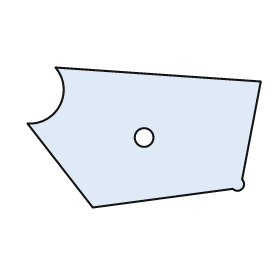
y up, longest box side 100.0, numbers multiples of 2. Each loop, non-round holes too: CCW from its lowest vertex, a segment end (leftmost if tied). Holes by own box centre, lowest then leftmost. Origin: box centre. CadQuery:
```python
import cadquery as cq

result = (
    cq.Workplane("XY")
    .moveTo(-22.0, -30.0)
    .lineTo(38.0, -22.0)
    .threePointArc((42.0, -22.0), (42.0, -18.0))
    .lineTo(50.0, 24.0)
    .lineTo(-38.0, 30.0)
    .threePointArc((-36.0, 14.0), (-50.0, 6.0))
    .close()
    .moveTo(0.0, 0.0)
    .circle(4.0)
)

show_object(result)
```